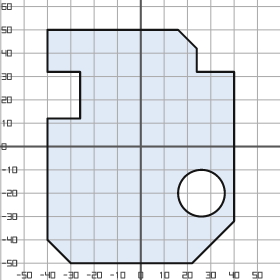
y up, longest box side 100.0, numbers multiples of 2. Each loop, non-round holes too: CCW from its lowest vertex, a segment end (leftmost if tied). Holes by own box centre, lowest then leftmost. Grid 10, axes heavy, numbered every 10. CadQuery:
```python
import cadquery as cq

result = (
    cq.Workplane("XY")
    .moveTo(-30.0, -50.0)
    .lineTo(22.0, -50.0)
    .lineTo(40.0, -32.0)
    .lineTo(40.0, 32.0)
    .lineTo(24.0, 32.0)
    .lineTo(24.0, 42.0)
    .lineTo(16.0, 50.0)
    .lineTo(-40.0, 50.0)
    .lineTo(-40.0, 32.0)
    .lineTo(-26.0, 32.0)
    .lineTo(-26.0, 12.0)
    .lineTo(-40.0, 12.0)
    .lineTo(-40.0, -40.0)
    .close()
    .moveTo(26.0, -20.0)
    .circle(10.0)
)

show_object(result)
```